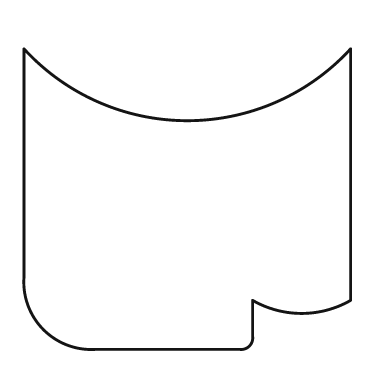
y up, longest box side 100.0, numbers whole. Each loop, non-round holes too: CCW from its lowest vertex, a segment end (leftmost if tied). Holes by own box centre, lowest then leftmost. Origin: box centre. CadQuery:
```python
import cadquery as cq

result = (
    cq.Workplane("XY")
    .moveTo(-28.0, -46.0)
    .lineTo(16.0, -46.0)
    .threePointArc((19.0, -45.0), (20.0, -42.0))
    .lineTo(20.0, -31.0)
    .threePointArc((35.0, -35.0), (50.0, -31.0))
    .lineTo(50.0, 46.0)
    .threePointArc((0.0, 24.0), (-50.0, 46.0))
    .lineTo(-50.0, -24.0)
    .threePointArc((-44.0, -40.0), (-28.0, -46.0))
    .close()
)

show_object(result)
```